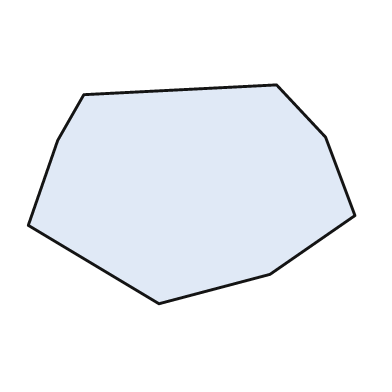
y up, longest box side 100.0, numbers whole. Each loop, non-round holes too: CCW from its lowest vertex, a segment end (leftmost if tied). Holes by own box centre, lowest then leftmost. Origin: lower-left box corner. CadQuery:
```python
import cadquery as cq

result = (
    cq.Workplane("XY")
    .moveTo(40.0, 0.0)
    .lineTo(74.0, 9.0)
    .lineTo(100.0, 27.0)
    .lineTo(91.0, 51.0)
    .lineTo(76.0, 67.0)
    .lineTo(17.0, 64.0)
    .lineTo(9.0, 50.0)
    .lineTo(0.0, 24.0)
    .close()
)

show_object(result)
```